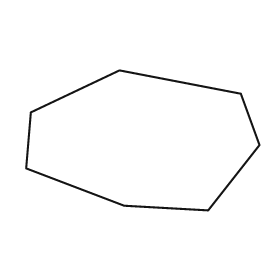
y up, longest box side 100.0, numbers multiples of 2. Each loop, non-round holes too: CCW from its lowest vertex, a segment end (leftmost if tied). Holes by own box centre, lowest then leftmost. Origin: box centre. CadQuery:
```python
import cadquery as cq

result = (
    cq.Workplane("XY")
    .moveTo(28.0, -30.0)
    .lineTo(50.0, -2.0)
    .lineTo(42.0, 20.0)
    .lineTo(-10.0, 30.0)
    .lineTo(-48.0, 12.0)
    .lineTo(-50.0, -12.0)
    .lineTo(-8.0, -28.0)
    .close()
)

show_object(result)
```